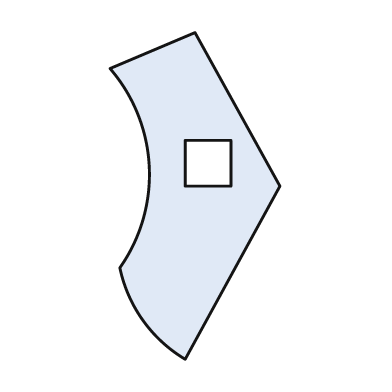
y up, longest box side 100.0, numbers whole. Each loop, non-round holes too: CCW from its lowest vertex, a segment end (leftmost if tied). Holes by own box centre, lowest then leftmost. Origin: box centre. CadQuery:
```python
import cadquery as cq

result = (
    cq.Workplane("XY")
    .moveTo(-3.0, -50.0)
    .lineTo(26.0, 3.0)
    .lineTo(0.0, 50.0)
    .lineTo(-26.0, 39.0)
    .threePointArc((-14.0, 9.0), (-23.0, -22.0))
    .threePointArc((-16.0, -38.0), (-3.0, -50.0))
    .close()
    .moveTo(-3.0, 3.0)
    .lineTo(11.0, 3.0)
    .lineTo(11.0, 17.0)
    .lineTo(-3.0, 17.0)
    .close()
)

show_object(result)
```